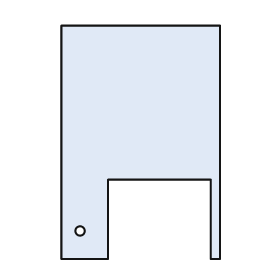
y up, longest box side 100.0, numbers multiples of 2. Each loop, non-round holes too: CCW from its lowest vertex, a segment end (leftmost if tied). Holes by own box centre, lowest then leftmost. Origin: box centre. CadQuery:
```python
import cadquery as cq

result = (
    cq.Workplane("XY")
    .moveTo(-34.0, -50.0)
    .lineTo(-14.0, -50.0)
    .lineTo(-14.0, -16.0)
    .lineTo(30.0, -16.0)
    .lineTo(30.0, -50.0)
    .lineTo(34.0, -50.0)
    .lineTo(34.0, 50.0)
    .lineTo(-34.0, 50.0)
    .close()
    .moveTo(-26.0, -38.0)
    .circle(2.0)
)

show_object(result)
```